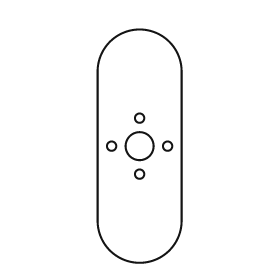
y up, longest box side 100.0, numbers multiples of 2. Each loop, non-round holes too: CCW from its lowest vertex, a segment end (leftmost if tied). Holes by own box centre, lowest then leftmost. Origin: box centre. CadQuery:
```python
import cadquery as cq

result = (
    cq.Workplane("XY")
    .moveTo(-18.0, -32.0)
    .threePointArc((0.0, -50.0), (18.0, -32.0))
    .lineTo(18.0, 32.0)
    .threePointArc((0.0, 50.0), (-18.0, 32.0))
    .close()
    .moveTo(0.0, -12.0)
    .circle(2.0)
    .moveTo(-12.0, 0.0)
    .circle(2.0)
    .moveTo(0.0, 0.0)
    .circle(6.0)
    .moveTo(12.0, 0.0)
    .circle(2.0)
    .moveTo(0.0, 12.0)
    .circle(2.0)
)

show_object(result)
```